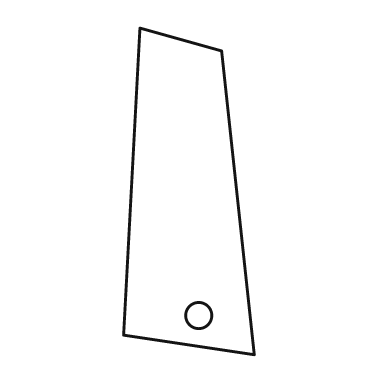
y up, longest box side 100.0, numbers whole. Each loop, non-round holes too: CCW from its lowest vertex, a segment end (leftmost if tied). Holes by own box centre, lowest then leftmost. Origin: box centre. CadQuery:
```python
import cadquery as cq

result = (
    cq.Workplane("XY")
    .moveTo(20.0, -50.0)
    .lineTo(10.0, 43.0)
    .lineTo(-15.0, 50.0)
    .lineTo(-20.0, -44.0)
    .close()
    .moveTo(3.0, -38.0)
    .circle(4.0)
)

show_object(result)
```